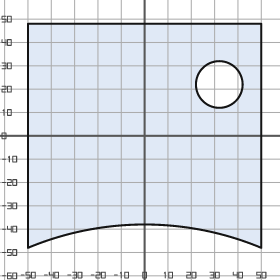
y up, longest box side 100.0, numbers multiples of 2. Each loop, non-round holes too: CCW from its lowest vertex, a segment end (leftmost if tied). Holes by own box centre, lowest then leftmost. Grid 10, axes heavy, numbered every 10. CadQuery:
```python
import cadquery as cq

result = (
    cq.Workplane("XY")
    .moveTo(-50.0, -48.0)
    .threePointArc((0.0, -38.0), (50.0, -48.0))
    .lineTo(50.0, 48.0)
    .lineTo(-50.0, 48.0)
    .close()
    .moveTo(32.0, 22.0)
    .circle(10.0)
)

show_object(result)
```